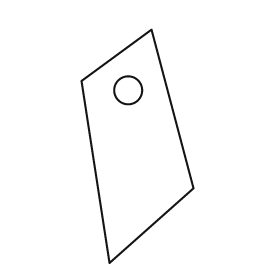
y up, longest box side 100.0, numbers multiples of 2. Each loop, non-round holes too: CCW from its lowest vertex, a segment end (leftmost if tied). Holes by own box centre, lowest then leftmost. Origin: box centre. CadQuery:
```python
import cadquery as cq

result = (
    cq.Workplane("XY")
    .moveTo(-12.0, -50.0)
    .lineTo(24.0, -18.0)
    .lineTo(6.0, 50.0)
    .lineTo(-24.0, 28.0)
    .close()
    .moveTo(-4.0, 24.0)
    .circle(6.0)
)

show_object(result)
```